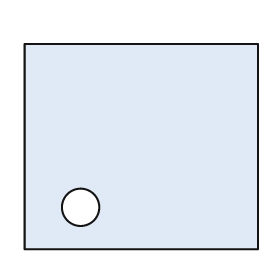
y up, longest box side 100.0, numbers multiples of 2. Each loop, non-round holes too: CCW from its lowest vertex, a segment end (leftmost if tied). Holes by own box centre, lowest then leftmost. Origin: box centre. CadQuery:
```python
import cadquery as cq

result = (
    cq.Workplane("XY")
    .moveTo(-50.0, -44.0)
    .lineTo(50.0, -44.0)
    .lineTo(50.0, 44.0)
    .lineTo(-50.0, 44.0)
    .close()
    .moveTo(-26.0, -26.0)
    .circle(8.0)
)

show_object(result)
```